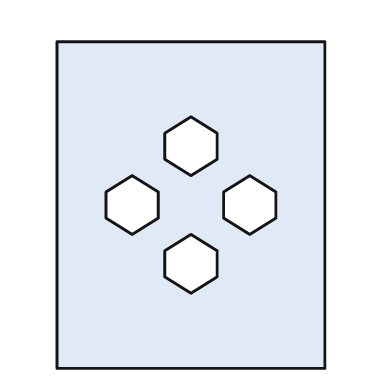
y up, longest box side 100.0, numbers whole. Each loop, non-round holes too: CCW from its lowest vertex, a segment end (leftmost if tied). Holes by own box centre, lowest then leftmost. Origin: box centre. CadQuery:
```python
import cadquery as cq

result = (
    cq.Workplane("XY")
    .moveTo(-41.0, -50.0)
    .lineTo(41.0, -50.0)
    .lineTo(41.0, 50.0)
    .lineTo(-41.0, 50.0)
    .close()
    .moveTo(0.0, -27.0)
    .lineTo(8.0, -22.0)
    .lineTo(8.0, -14.0)
    .lineTo(0.0, -9.0)
    .lineTo(-8.0, -14.0)
    .lineTo(-8.0, -22.0)
    .close()
    .moveTo(-18.0, -9.0)
    .lineTo(-10.0, -4.0)
    .lineTo(-10.0, 4.0)
    .lineTo(-18.0, 9.0)
    .lineTo(-26.0, 4.0)
    .lineTo(-26.0, -4.0)
    .close()
    .moveTo(18.0, -9.0)
    .lineTo(26.0, -4.0)
    .lineTo(26.0, 4.0)
    .lineTo(18.0, 9.0)
    .lineTo(10.0, 4.0)
    .lineTo(10.0, -4.0)
    .close()
    .moveTo(0.0, 9.0)
    .lineTo(8.0, 14.0)
    .lineTo(8.0, 22.0)
    .lineTo(0.0, 27.0)
    .lineTo(-8.0, 22.0)
    .lineTo(-8.0, 14.0)
    .close()
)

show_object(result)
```